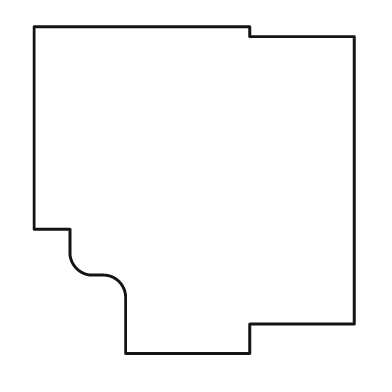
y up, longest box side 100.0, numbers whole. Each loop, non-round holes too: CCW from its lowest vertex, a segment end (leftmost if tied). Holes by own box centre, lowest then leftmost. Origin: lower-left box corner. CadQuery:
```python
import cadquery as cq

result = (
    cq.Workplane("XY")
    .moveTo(28.0, 0.0)
    .lineTo(66.0, 0.0)
    .lineTo(66.0, 9.0)
    .lineTo(98.0, 9.0)
    .lineTo(98.0, 97.0)
    .lineTo(66.0, 97.0)
    .lineTo(66.0, 100.0)
    .lineTo(0.0, 100.0)
    .lineTo(0.0, 38.0)
    .lineTo(11.0, 38.0)
    .lineTo(11.0, 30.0)
    .threePointArc((13.0, 26.0), (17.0, 24.0))
    .lineTo(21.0, 24.0)
    .threePointArc((26.0, 22.0), (28.0, 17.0))
    .close()
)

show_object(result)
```